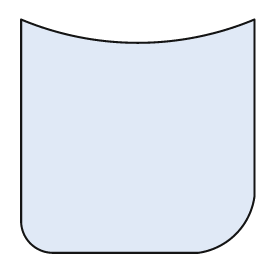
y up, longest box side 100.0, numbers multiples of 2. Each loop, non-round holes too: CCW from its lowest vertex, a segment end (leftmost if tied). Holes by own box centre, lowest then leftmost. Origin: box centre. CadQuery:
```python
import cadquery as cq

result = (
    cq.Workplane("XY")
    .moveTo(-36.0, -50.0)
    .lineTo(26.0, -50.0)
    .threePointArc((42.0, -42.0), (50.0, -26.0))
    .lineTo(50.0, 50.0)
    .threePointArc((0.0, 40.0), (-50.0, 50.0))
    .lineTo(-50.0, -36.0)
    .threePointArc((-46.0, -46.0), (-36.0, -50.0))
    .close()
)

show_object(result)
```